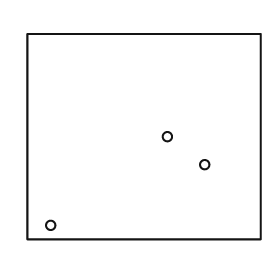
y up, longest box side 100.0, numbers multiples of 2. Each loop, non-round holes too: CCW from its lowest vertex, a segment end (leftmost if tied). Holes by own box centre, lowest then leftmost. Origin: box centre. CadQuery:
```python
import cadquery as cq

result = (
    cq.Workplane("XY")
    .moveTo(-50.0, -44.0)
    .lineTo(50.0, -44.0)
    .lineTo(50.0, 44.0)
    .lineTo(-50.0, 44.0)
    .close()
    .moveTo(-40.0, -38.0)
    .circle(2.0)
    .moveTo(26.0, -12.0)
    .circle(2.0)
    .moveTo(10.0, 0.0)
    .circle(2.0)
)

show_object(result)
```